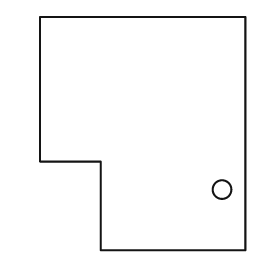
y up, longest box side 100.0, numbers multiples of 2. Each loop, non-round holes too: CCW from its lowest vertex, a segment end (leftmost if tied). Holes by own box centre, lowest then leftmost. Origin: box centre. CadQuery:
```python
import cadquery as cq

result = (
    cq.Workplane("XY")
    .moveTo(-18.0, -50.0)
    .lineTo(44.0, -50.0)
    .lineTo(44.0, 50.0)
    .lineTo(-44.0, 50.0)
    .lineTo(-44.0, -12.0)
    .lineTo(-18.0, -12.0)
    .close()
    .moveTo(34.0, -24.0)
    .circle(4.0)
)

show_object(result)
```